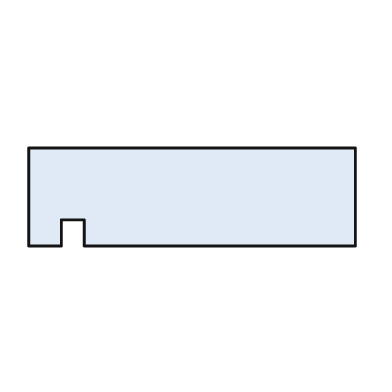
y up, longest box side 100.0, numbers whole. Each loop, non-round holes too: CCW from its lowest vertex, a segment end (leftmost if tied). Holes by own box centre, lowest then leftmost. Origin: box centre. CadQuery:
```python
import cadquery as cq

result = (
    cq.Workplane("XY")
    .moveTo(-50.0, -15.0)
    .lineTo(-40.0, -15.0)
    .lineTo(-40.0, -7.0)
    .lineTo(-33.0, -7.0)
    .lineTo(-33.0, -15.0)
    .lineTo(50.0, -15.0)
    .lineTo(50.0, 15.0)
    .lineTo(-50.0, 15.0)
    .close()
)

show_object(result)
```